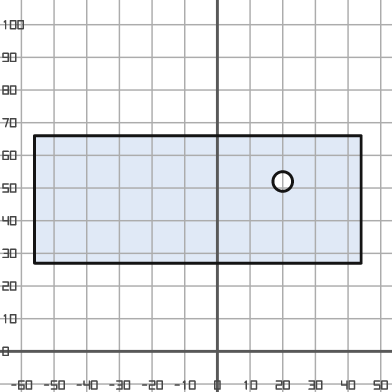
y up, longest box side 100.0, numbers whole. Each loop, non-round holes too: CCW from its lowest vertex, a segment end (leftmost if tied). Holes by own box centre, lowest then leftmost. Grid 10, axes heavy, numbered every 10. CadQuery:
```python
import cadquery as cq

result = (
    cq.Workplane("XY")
    .moveTo(-56.0, 27.0)
    .lineTo(44.0, 27.0)
    .lineTo(44.0, 66.0)
    .lineTo(-56.0, 66.0)
    .close()
    .moveTo(20.0, 52.0)
    .circle(3.0)
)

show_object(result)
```